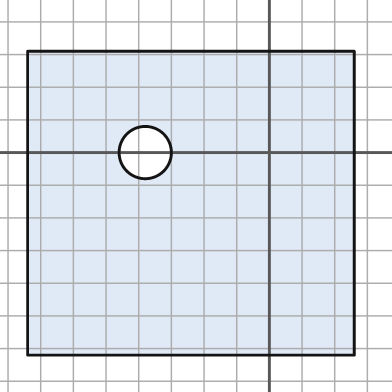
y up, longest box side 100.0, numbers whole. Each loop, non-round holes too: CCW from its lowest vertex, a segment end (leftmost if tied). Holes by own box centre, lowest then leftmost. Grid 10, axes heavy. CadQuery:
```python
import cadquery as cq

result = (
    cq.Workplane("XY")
    .moveTo(-74.0, -62.0)
    .lineTo(26.0, -62.0)
    .lineTo(26.0, 31.0)
    .lineTo(-74.0, 31.0)
    .close()
    .moveTo(-38.0, 0.0)
    .circle(8.0)
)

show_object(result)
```